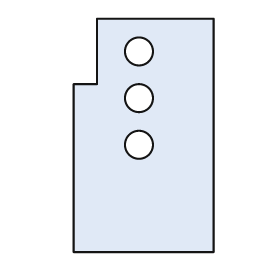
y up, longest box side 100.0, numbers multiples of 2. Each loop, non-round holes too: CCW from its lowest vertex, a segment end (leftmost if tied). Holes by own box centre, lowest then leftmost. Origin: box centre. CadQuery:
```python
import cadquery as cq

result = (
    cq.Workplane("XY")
    .moveTo(-30.0, -50.0)
    .lineTo(30.0, -50.0)
    .lineTo(30.0, 50.0)
    .lineTo(-20.0, 50.0)
    .lineTo(-20.0, 22.0)
    .lineTo(-30.0, 22.0)
    .close()
    .moveTo(-2.0, -4.0)
    .circle(6.0)
    .moveTo(-2.0, 16.0)
    .circle(6.0)
    .moveTo(-2.0, 36.0)
    .circle(6.0)
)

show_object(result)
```